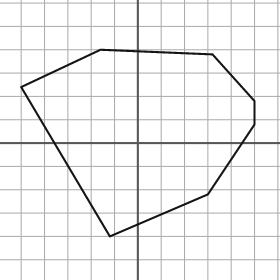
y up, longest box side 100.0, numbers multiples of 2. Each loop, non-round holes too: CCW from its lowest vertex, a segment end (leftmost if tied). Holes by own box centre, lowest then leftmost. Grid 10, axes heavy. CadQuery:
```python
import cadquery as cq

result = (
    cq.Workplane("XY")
    .moveTo(-12.0, -40.0)
    .lineTo(30.0, -22.0)
    .lineTo(50.0, 8.0)
    .lineTo(50.0, 18.0)
    .lineTo(32.0, 38.0)
    .lineTo(-16.0, 40.0)
    .lineTo(-50.0, 24.0)
    .close()
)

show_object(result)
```